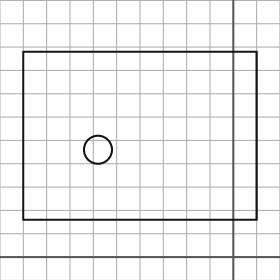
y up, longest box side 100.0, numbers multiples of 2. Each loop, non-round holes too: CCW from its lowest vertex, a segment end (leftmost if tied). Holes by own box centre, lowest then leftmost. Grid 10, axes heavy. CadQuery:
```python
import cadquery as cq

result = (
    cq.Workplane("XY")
    .moveTo(-90.0, 16.0)
    .lineTo(10.0, 16.0)
    .lineTo(10.0, 88.0)
    .lineTo(-90.0, 88.0)
    .close()
    .moveTo(-58.0, 46.0)
    .circle(6.0)
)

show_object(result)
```